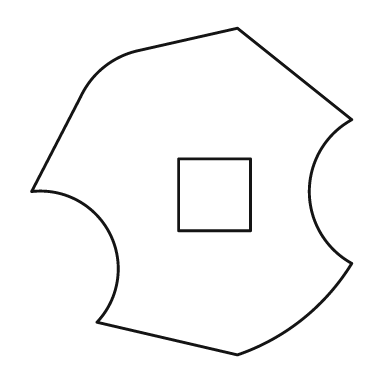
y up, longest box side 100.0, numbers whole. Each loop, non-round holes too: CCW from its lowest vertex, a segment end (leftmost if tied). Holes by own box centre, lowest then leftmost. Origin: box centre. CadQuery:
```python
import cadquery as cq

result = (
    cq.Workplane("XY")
    .moveTo(14.0, -50.0)
    .threePointArc((34.0, -39.0), (49.0, -22.0))
    .threePointArc((36.0, 0.0), (49.0, 22.0))
    .lineTo(14.0, 50.0)
    .lineTo(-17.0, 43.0)
    .threePointArc((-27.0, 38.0), (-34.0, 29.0))
    .lineTo(-49.0, 0.0)
    .threePointArc((-25.0, -13.0), (-29.0, -40.0))
    .close()
    .moveTo(-4.0, -12.0)
    .lineTo(18.0, -12.0)
    .lineTo(18.0, 10.0)
    .lineTo(-4.0, 10.0)
    .close()
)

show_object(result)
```